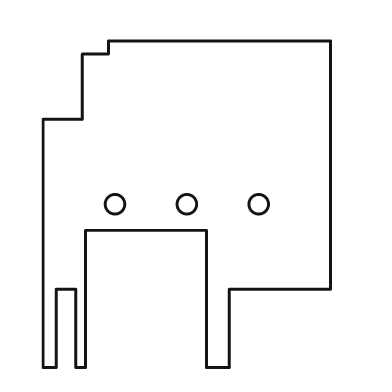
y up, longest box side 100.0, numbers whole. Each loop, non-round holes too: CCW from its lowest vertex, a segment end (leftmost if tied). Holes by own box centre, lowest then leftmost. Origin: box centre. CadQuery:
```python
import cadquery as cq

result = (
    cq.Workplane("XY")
    .moveTo(-44.0, -50.0)
    .lineTo(-40.0, -50.0)
    .lineTo(-40.0, -26.0)
    .lineTo(-34.0, -26.0)
    .lineTo(-34.0, -50.0)
    .lineTo(-31.0, -50.0)
    .lineTo(-31.0, -8.0)
    .lineTo(6.0, -8.0)
    .lineTo(6.0, -50.0)
    .lineTo(13.0, -50.0)
    .lineTo(13.0, -26.0)
    .lineTo(44.0, -26.0)
    .lineTo(44.0, 50.0)
    .lineTo(-24.0, 50.0)
    .lineTo(-24.0, 46.0)
    .lineTo(-32.0, 46.0)
    .lineTo(-32.0, 26.0)
    .lineTo(-44.0, 26.0)
    .close()
    .moveTo(-22.0, 0.0)
    .circle(3.0)
    .moveTo(0.0, 0.0)
    .circle(3.0)
    .moveTo(22.0, 0.0)
    .circle(3.0)
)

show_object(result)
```